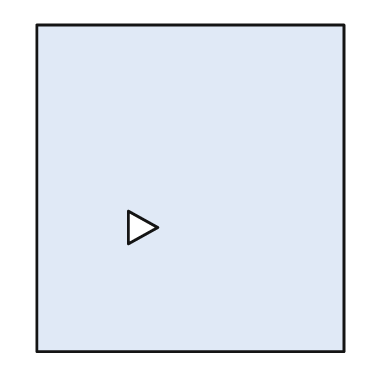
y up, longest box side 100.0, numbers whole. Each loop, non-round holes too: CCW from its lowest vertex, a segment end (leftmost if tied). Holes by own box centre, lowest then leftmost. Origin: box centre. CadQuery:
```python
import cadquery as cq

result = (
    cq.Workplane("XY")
    .moveTo(-47.0, -50.0)
    .lineTo(47.0, -50.0)
    .lineTo(47.0, 50.0)
    .lineTo(-47.0, 50.0)
    .close()
    .moveTo(-19.0, -17.0)
    .lineTo(-10.0, -12.0)
    .lineTo(-19.0, -7.0)
    .close()
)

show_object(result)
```